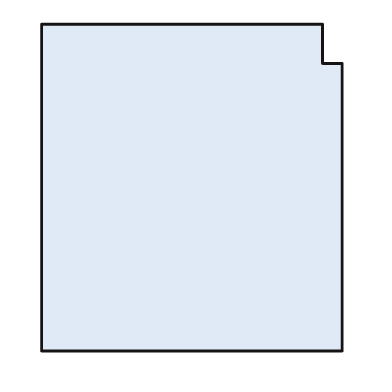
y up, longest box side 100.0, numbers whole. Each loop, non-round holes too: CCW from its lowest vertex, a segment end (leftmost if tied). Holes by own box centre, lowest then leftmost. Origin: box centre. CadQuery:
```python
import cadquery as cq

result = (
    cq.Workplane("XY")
    .moveTo(-46.0, -50.0)
    .lineTo(46.0, -50.0)
    .lineTo(46.0, 38.0)
    .lineTo(40.0, 38.0)
    .lineTo(40.0, 50.0)
    .lineTo(-46.0, 50.0)
    .close()
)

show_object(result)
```